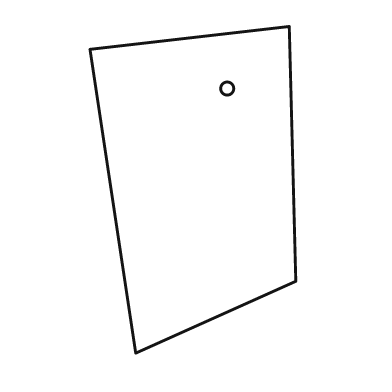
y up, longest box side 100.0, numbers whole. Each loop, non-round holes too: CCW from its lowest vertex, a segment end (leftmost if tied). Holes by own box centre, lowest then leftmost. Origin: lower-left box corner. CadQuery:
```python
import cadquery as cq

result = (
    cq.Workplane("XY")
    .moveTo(14.0, 0.0)
    .lineTo(63.0, 22.0)
    .lineTo(61.0, 100.0)
    .lineTo(0.0, 93.0)
    .close()
    .moveTo(42.0, 81.0)
    .circle(2.0)
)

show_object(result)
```